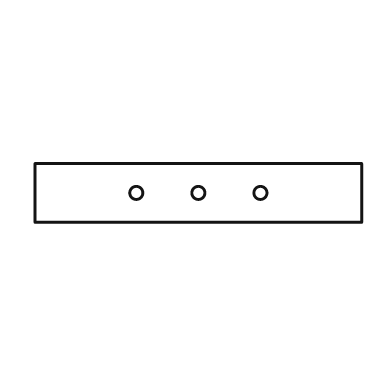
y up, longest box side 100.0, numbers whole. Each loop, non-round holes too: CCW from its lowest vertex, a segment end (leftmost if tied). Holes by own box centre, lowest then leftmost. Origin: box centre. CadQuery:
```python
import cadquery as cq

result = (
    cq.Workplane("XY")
    .moveTo(-50.0, -9.0)
    .lineTo(50.0, -9.0)
    .lineTo(50.0, 9.0)
    .lineTo(-50.0, 9.0)
    .close()
    .moveTo(-19.0, 0.0)
    .circle(2.0)
    .moveTo(0.0, 0.0)
    .circle(2.0)
    .moveTo(19.0, 0.0)
    .circle(2.0)
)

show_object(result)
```